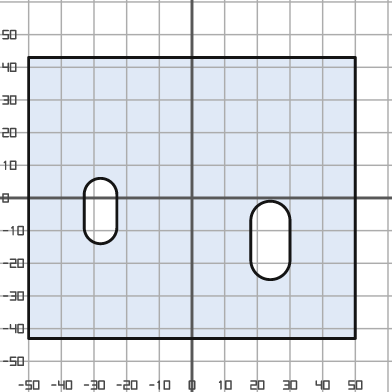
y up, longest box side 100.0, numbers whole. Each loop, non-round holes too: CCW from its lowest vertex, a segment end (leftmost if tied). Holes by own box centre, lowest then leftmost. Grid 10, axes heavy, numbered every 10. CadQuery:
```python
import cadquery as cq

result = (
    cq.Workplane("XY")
    .moveTo(-50.0, -43.0)
    .lineTo(50.0, -43.0)
    .lineTo(50.0, 43.0)
    .lineTo(-50.0, 43.0)
    .close()
    .moveTo(18.0, -19.0)
    .threePointArc((24.0, -25.0), (30.0, -19.0))
    .lineTo(30.0, -7.0)
    .threePointArc((24.0, -1.0), (18.0, -7.0))
    .close()
    .moveTo(-33.0, -9.0)
    .threePointArc((-28.0, -14.0), (-23.0, -9.0))
    .lineTo(-23.0, 1.0)
    .threePointArc((-28.0, 6.0), (-33.0, 1.0))
    .close()
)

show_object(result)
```